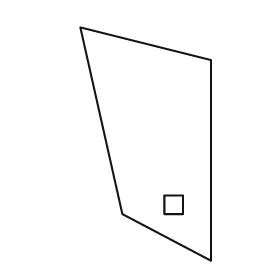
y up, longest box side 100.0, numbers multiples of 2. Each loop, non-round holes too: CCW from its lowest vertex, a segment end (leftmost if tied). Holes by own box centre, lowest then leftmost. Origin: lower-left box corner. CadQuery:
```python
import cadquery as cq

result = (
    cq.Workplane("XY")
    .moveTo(56.0, 0.0)
    .lineTo(56.0, 86.0)
    .lineTo(0.0, 100.0)
    .lineTo(18.0, 20.0)
    .close()
    .moveTo(36.0, 20.0)
    .lineTo(44.0, 20.0)
    .lineTo(44.0, 28.0)
    .lineTo(36.0, 28.0)
    .close()
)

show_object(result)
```